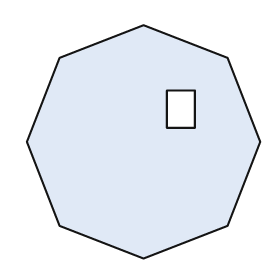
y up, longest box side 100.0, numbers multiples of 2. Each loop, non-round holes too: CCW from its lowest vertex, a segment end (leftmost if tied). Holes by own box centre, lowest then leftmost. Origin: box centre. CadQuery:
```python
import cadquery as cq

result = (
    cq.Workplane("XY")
    .moveTo(0.0, -50.0)
    .lineTo(36.0, -36.0)
    .lineTo(50.0, 0.0)
    .lineTo(36.0, 36.0)
    .lineTo(0.0, 50.0)
    .lineTo(-36.0, 36.0)
    .lineTo(-50.0, 0.0)
    .lineTo(-36.0, -36.0)
    .close()
    .moveTo(10.0, 6.0)
    .lineTo(22.0, 6.0)
    .lineTo(22.0, 22.0)
    .lineTo(10.0, 22.0)
    .close()
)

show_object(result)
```